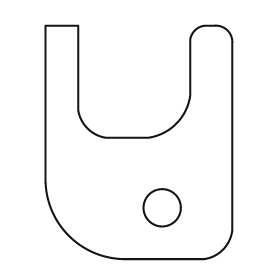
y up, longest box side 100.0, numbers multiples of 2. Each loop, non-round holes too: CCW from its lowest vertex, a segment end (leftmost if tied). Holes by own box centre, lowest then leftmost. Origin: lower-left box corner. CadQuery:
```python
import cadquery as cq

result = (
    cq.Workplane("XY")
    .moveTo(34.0, 0.0)
    .lineTo(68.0, 0.0)
    .threePointArc((76.0, 4.0), (80.0, 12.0))
    .lineTo(80.0, 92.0)
    .threePointArc((78.0, 98.0), (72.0, 100.0))
    .lineTo(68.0, 100.0)
    .threePointArc((64.0, 98.0), (62.0, 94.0))
    .lineTo(62.0, 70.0)
    .threePointArc((56.0, 58.0), (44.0, 52.0))
    .lineTo(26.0, 52.0)
    .threePointArc((18.0, 56.0), (14.0, 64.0))
    .lineTo(14.0, 100.0)
    .lineTo(0.0, 100.0)
    .lineTo(0.0, 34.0)
    .threePointArc((10.0, 10.0), (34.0, 0.0))
    .close()
    .moveTo(50.0, 22.0)
    .circle(8.0)
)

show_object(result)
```